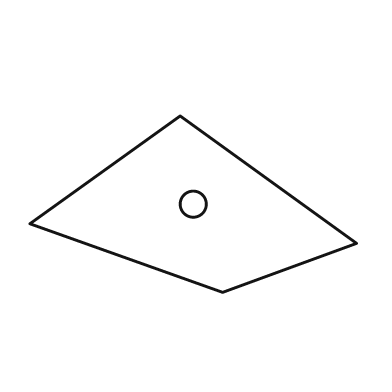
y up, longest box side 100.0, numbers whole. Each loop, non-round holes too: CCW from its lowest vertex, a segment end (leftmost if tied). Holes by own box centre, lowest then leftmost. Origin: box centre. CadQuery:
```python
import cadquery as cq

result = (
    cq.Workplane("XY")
    .moveTo(9.0, -27.0)
    .lineTo(50.0, -12.0)
    .lineTo(-4.0, 27.0)
    .lineTo(-50.0, -6.0)
    .close()
    .moveTo(0.0, 0.0)
    .circle(4.0)
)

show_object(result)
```